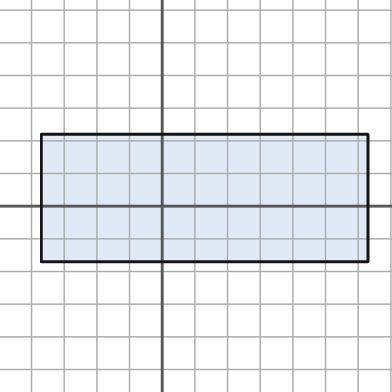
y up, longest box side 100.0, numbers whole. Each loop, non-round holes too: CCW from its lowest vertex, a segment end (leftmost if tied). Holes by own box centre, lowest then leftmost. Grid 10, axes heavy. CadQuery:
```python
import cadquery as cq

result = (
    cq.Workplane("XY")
    .moveTo(-37.0, -17.0)
    .lineTo(63.0, -17.0)
    .lineTo(63.0, 22.0)
    .lineTo(-37.0, 22.0)
    .close()
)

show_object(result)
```